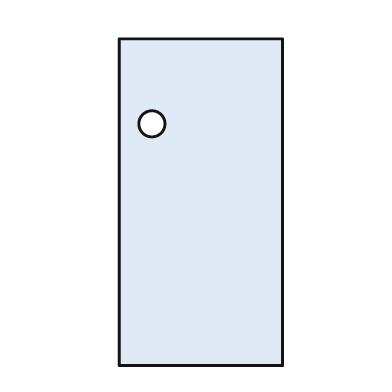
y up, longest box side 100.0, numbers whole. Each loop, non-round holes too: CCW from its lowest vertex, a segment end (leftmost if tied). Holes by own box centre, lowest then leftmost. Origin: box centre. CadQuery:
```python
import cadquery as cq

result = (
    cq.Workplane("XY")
    .moveTo(-25.0, -50.0)
    .lineTo(25.0, -50.0)
    .lineTo(25.0, 50.0)
    .lineTo(-25.0, 50.0)
    .close()
    .moveTo(-15.0, 24.0)
    .circle(4.0)
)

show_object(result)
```